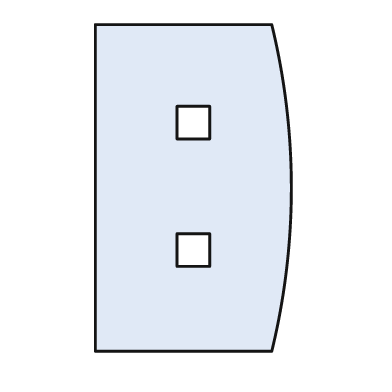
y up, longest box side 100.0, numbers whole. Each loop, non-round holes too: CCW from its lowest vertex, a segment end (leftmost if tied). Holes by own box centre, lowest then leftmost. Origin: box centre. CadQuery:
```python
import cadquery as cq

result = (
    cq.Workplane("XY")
    .moveTo(-30.0, -50.0)
    .lineTo(24.0, -50.0)
    .threePointArc((30.0, 0.0), (24.0, 50.0))
    .lineTo(-30.0, 50.0)
    .close()
    .moveTo(-5.0, -24.0)
    .lineTo(5.0, -24.0)
    .lineTo(5.0, -14.0)
    .lineTo(-5.0, -14.0)
    .close()
    .moveTo(-5.0, 15.0)
    .lineTo(5.0, 15.0)
    .lineTo(5.0, 25.0)
    .lineTo(-5.0, 25.0)
    .close()
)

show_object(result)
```